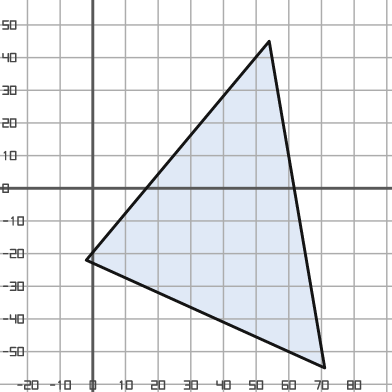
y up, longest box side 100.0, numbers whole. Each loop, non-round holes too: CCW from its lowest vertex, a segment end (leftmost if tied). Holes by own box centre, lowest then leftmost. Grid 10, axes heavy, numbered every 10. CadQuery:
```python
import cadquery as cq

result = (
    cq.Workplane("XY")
    .moveTo(71.0, -55.0)
    .lineTo(54.0, 45.0)
    .lineTo(-2.0, -22.0)
    .close()
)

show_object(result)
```